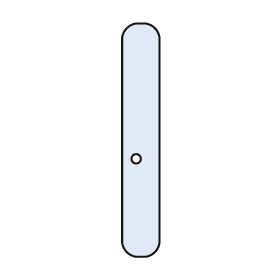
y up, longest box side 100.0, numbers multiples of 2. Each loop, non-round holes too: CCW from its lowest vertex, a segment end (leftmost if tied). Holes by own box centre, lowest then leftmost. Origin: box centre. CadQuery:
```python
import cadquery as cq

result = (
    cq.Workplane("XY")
    .moveTo(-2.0, -50.0)
    .lineTo(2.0, -50.0)
    .threePointArc((6.0, -48.0), (8.0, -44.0))
    .lineTo(8.0, 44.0)
    .threePointArc((6.0, 48.0), (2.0, 50.0))
    .lineTo(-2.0, 50.0)
    .threePointArc((-6.0, 48.0), (-8.0, 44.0))
    .lineTo(-8.0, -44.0)
    .threePointArc((-6.0, -48.0), (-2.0, -50.0))
    .close()
    .moveTo(-2.0, -8.0)
    .circle(2.0)
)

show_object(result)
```